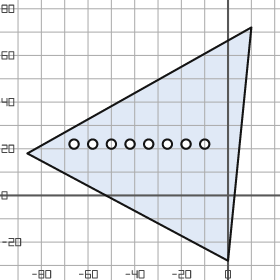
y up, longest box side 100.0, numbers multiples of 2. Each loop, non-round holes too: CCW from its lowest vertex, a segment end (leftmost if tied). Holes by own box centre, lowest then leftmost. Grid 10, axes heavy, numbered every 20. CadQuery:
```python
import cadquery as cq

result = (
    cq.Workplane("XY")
    .moveTo(0.0, -28.0)
    .lineTo(10.0, 72.0)
    .lineTo(-86.0, 18.0)
    .close()
    .moveTo(-66.0, 22.0)
    .circle(2.0)
    .moveTo(-58.0, 22.0)
    .circle(2.0)
    .moveTo(-50.0, 22.0)
    .circle(2.0)
    .moveTo(-42.0, 22.0)
    .circle(2.0)
    .moveTo(-34.0, 22.0)
    .circle(2.0)
    .moveTo(-26.0, 22.0)
    .circle(2.0)
    .moveTo(-18.0, 22.0)
    .circle(2.0)
    .moveTo(-10.0, 22.0)
    .circle(2.0)
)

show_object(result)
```